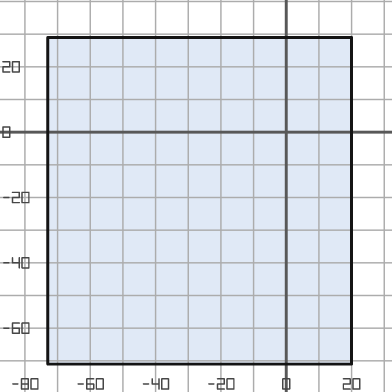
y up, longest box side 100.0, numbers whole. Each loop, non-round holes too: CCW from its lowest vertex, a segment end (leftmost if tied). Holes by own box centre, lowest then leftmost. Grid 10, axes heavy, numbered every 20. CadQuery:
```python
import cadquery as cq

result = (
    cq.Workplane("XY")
    .moveTo(-73.0, -71.0)
    .lineTo(20.0, -71.0)
    .lineTo(20.0, 29.0)
    .lineTo(-73.0, 29.0)
    .close()
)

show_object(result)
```